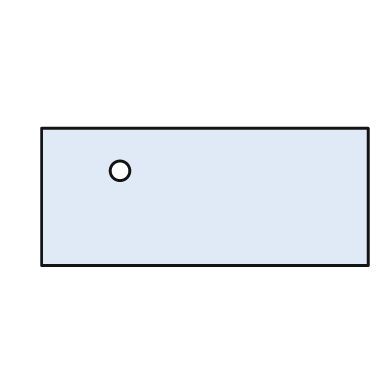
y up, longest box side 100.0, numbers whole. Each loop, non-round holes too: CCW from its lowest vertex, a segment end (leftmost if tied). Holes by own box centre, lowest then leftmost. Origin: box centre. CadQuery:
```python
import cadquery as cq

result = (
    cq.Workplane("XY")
    .moveTo(-50.0, -21.0)
    .lineTo(50.0, -21.0)
    .lineTo(50.0, 21.0)
    .lineTo(-50.0, 21.0)
    .close()
    .moveTo(-26.0, 8.0)
    .circle(3.0)
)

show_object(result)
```